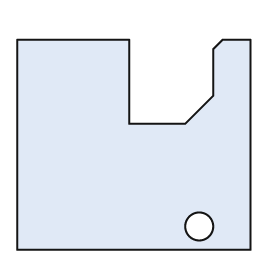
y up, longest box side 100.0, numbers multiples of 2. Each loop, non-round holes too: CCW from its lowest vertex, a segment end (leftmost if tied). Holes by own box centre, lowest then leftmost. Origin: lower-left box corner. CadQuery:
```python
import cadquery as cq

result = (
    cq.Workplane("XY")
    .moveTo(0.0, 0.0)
    .lineTo(100.0, 0.0)
    .lineTo(100.0, 90.0)
    .lineTo(88.0, 90.0)
    .lineTo(84.0, 86.0)
    .lineTo(84.0, 66.0)
    .lineTo(72.0, 54.0)
    .lineTo(48.0, 54.0)
    .lineTo(48.0, 90.0)
    .lineTo(0.0, 90.0)
    .close()
    .moveTo(78.0, 10.0)
    .circle(6.0)
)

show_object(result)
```